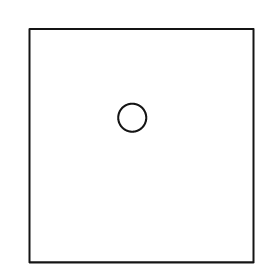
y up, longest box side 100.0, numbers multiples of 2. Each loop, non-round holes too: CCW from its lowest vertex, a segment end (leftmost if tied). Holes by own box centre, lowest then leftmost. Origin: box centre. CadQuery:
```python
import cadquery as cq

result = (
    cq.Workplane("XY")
    .moveTo(-48.0, -50.0)
    .lineTo(48.0, -50.0)
    .lineTo(48.0, 50.0)
    .lineTo(-48.0, 50.0)
    .close()
    .moveTo(-4.0, 12.0)
    .circle(6.0)
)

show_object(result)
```